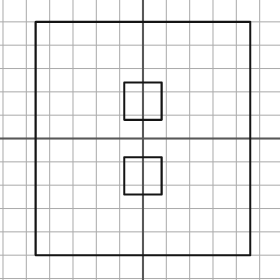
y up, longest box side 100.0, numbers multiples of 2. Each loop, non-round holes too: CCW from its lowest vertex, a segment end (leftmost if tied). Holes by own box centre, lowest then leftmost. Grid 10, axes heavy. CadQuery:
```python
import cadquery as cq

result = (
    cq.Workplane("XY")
    .moveTo(-46.0, -50.0)
    .lineTo(46.0, -50.0)
    .lineTo(46.0, 50.0)
    .lineTo(-46.0, 50.0)
    .close()
    .moveTo(-8.0, -24.0)
    .lineTo(8.0, -24.0)
    .lineTo(8.0, -8.0)
    .lineTo(-8.0, -8.0)
    .close()
    .moveTo(-8.0, 8.0)
    .lineTo(8.0, 8.0)
    .lineTo(8.0, 24.0)
    .lineTo(-8.0, 24.0)
    .close()
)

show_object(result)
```